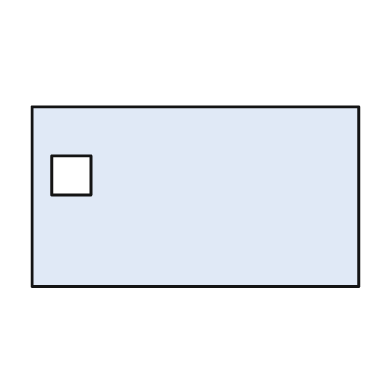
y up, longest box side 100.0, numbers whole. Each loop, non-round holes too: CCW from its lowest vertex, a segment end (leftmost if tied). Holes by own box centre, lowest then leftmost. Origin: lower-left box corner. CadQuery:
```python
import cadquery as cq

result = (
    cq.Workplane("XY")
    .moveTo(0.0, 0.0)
    .lineTo(100.0, 0.0)
    .lineTo(100.0, 55.0)
    .lineTo(0.0, 55.0)
    .close()
    .moveTo(6.0, 28.0)
    .lineTo(18.0, 28.0)
    .lineTo(18.0, 40.0)
    .lineTo(6.0, 40.0)
    .close()
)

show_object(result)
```